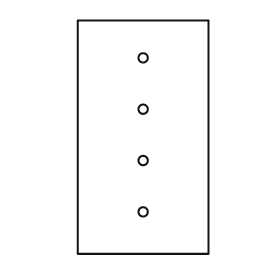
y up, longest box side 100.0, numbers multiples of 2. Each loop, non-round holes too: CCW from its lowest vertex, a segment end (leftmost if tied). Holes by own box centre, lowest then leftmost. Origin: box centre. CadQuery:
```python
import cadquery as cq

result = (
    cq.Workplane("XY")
    .moveTo(-28.0, -50.0)
    .lineTo(28.0, -50.0)
    .lineTo(28.0, 50.0)
    .lineTo(-28.0, 50.0)
    .close()
    .moveTo(0.0, -32.0)
    .circle(2.0)
    .moveTo(0.0, -10.0)
    .circle(2.0)
    .moveTo(0.0, 12.0)
    .circle(2.0)
    .moveTo(0.0, 34.0)
    .circle(2.0)
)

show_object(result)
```